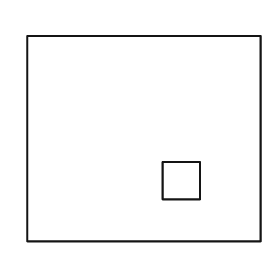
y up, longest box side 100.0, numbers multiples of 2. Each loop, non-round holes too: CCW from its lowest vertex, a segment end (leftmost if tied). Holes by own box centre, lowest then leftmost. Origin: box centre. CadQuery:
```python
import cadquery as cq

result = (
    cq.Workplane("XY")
    .moveTo(-50.0, -44.0)
    .lineTo(50.0, -44.0)
    .lineTo(50.0, 44.0)
    .lineTo(-50.0, 44.0)
    .close()
    .moveTo(8.0, -26.0)
    .lineTo(24.0, -26.0)
    .lineTo(24.0, -10.0)
    .lineTo(8.0, -10.0)
    .close()
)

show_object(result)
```